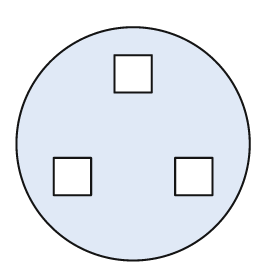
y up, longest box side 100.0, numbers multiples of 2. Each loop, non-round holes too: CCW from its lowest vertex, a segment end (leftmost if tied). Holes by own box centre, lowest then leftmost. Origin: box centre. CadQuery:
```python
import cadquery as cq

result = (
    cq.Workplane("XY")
    .moveTo(0.0, 0.0)
    .circle(50.0)
    .moveTo(-34.0, -22.0)
    .lineTo(-18.0, -22.0)
    .lineTo(-18.0, -6.0)
    .lineTo(-34.0, -6.0)
    .close()
    .moveTo(18.0, -22.0)
    .lineTo(34.0, -22.0)
    .lineTo(34.0, -6.0)
    .lineTo(18.0, -6.0)
    .close()
    .moveTo(-8.0, 22.0)
    .lineTo(8.0, 22.0)
    .lineTo(8.0, 38.0)
    .lineTo(-8.0, 38.0)
    .close()
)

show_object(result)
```